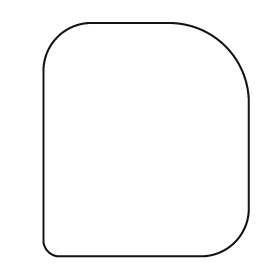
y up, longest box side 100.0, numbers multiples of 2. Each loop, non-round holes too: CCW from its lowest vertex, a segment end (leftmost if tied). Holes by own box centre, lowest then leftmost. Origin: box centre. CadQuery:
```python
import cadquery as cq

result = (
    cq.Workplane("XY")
    .moveTo(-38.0, -50.0)
    .lineTo(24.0, -50.0)
    .threePointArc((38.0, -44.0), (44.0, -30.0))
    .lineTo(44.0, 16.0)
    .threePointArc((34.0, 40.0), (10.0, 50.0))
    .lineTo(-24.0, 50.0)
    .threePointArc((-38.0, 44.0), (-44.0, 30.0))
    .lineTo(-44.0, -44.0)
    .threePointArc((-42.0, -48.0), (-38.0, -50.0))
    .close()
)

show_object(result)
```